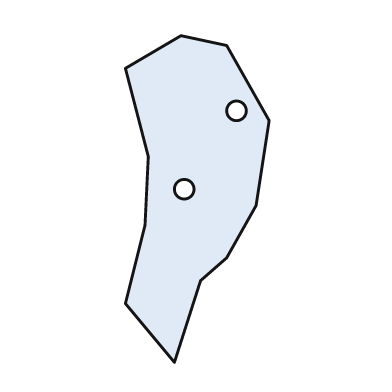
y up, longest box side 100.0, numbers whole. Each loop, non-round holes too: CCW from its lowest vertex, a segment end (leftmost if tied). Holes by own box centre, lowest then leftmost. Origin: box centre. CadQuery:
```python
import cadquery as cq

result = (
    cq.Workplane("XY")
    .moveTo(-7.0, -50.0)
    .lineTo(1.0, -25.0)
    .lineTo(9.0, -18.0)
    .lineTo(18.0, -2.0)
    .lineTo(22.0, 24.0)
    .lineTo(9.0, 47.0)
    .lineTo(-5.0, 50.0)
    .lineTo(-22.0, 40.0)
    .lineTo(-15.0, 13.0)
    .lineTo(-16.0, -8.0)
    .lineTo(-22.0, -32.0)
    .close()
    .moveTo(-4.0, 3.0)
    .circle(3.0)
    .moveTo(12.0, 27.0)
    .circle(3.0)
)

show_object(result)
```